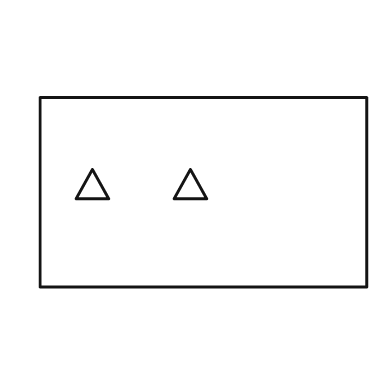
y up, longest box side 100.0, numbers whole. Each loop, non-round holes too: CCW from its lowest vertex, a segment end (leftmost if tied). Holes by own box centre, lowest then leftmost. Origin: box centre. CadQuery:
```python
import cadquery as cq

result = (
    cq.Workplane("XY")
    .moveTo(-50.0, -29.0)
    .lineTo(50.0, -29.0)
    .lineTo(50.0, 29.0)
    .lineTo(-50.0, 29.0)
    .close()
    .moveTo(-39.0, -2.0)
    .lineTo(-29.0, -2.0)
    .lineTo(-34.0, 7.0)
    .close()
    .moveTo(-9.0, -2.0)
    .lineTo(1.0, -2.0)
    .lineTo(-4.0, 7.0)
    .close()
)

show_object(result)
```